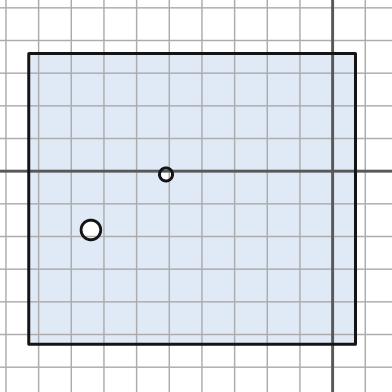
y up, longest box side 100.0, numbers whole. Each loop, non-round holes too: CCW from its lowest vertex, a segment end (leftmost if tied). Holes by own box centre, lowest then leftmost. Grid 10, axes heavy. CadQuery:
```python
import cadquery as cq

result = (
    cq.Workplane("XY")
    .moveTo(-93.0, -53.0)
    .lineTo(7.0, -53.0)
    .lineTo(7.0, 36.0)
    .lineTo(-93.0, 36.0)
    .close()
    .moveTo(-74.0, -18.0)
    .circle(3.0)
    .moveTo(-51.0, -1.0)
    .circle(2.0)
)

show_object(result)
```